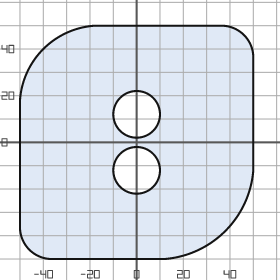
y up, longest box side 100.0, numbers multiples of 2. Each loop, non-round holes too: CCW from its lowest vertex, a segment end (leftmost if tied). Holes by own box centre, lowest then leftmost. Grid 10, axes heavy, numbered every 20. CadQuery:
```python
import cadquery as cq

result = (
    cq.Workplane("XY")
    .moveTo(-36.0, -50.0)
    .lineTo(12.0, -50.0)
    .threePointArc((38.0, -38.0), (50.0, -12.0))
    .lineTo(50.0, 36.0)
    .threePointArc((46.0, 46.0), (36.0, 50.0))
    .lineTo(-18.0, 50.0)
    .threePointArc((-40.0, 40.0), (-50.0, 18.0))
    .lineTo(-50.0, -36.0)
    .threePointArc((-46.0, -46.0), (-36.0, -50.0))
    .close()
    .moveTo(0.0, -12.0)
    .circle(10.0)
    .moveTo(0.0, 12.0)
    .circle(10.0)
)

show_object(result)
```